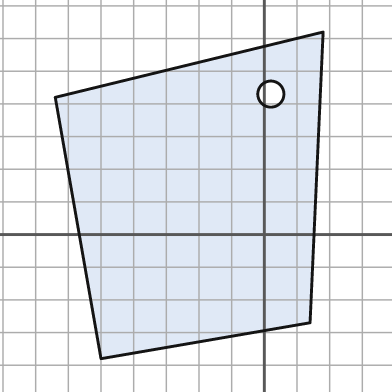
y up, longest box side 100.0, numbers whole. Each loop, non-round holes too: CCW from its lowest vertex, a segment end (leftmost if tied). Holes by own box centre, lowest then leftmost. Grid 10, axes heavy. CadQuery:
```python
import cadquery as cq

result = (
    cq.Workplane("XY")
    .moveTo(-50.0, -38.0)
    .lineTo(14.0, -27.0)
    .lineTo(18.0, 62.0)
    .lineTo(-64.0, 42.0)
    .close()
    .moveTo(2.0, 43.0)
    .circle(4.0)
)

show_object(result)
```